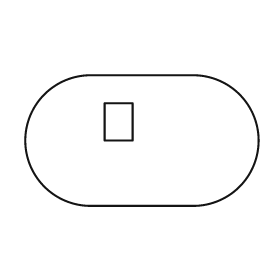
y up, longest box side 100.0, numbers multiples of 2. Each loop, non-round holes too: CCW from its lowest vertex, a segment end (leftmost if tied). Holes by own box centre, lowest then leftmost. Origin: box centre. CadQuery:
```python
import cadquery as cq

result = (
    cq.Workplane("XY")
    .moveTo(-22.0, -28.0)
    .lineTo(22.0, -28.0)
    .threePointArc((50.0, 0.0), (22.0, 28.0))
    .lineTo(-22.0, 28.0)
    .threePointArc((-50.0, 0.0), (-22.0, -28.0))
    .close()
    .moveTo(-16.0, 0.0)
    .lineTo(-4.0, 0.0)
    .lineTo(-4.0, 16.0)
    .lineTo(-16.0, 16.0)
    .close()
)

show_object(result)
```